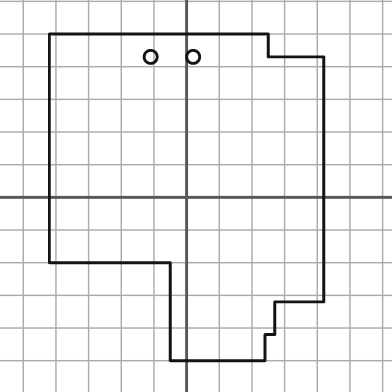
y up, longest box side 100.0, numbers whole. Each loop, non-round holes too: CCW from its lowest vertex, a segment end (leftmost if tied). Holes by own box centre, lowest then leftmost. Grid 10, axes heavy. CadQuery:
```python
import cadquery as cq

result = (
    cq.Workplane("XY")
    .moveTo(-5.0, -50.0)
    .lineTo(24.0, -50.0)
    .lineTo(24.0, -42.0)
    .lineTo(27.0, -42.0)
    .lineTo(27.0, -32.0)
    .lineTo(42.0, -32.0)
    .lineTo(42.0, 43.0)
    .lineTo(25.0, 43.0)
    .lineTo(25.0, 50.0)
    .lineTo(-42.0, 50.0)
    .lineTo(-42.0, -20.0)
    .lineTo(-5.0, -20.0)
    .close()
    .moveTo(-11.0, 43.0)
    .circle(2.0)
    .moveTo(2.0, 43.0)
    .circle(2.0)
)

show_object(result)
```